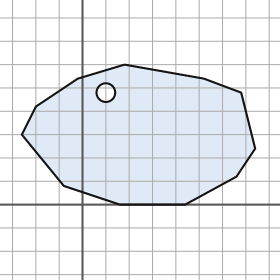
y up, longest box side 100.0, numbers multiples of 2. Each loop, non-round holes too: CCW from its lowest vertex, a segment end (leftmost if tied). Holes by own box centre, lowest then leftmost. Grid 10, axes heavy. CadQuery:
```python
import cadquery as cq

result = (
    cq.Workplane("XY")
    .moveTo(16.0, 0.0)
    .lineTo(44.0, 0.0)
    .lineTo(66.0, 12.0)
    .lineTo(74.0, 24.0)
    .lineTo(68.0, 48.0)
    .lineTo(52.0, 54.0)
    .lineTo(18.0, 60.0)
    .lineTo(-2.0, 54.0)
    .lineTo(-20.0, 42.0)
    .lineTo(-26.0, 30.0)
    .lineTo(-8.0, 8.0)
    .close()
    .moveTo(10.0, 48.0)
    .circle(4.0)
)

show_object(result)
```